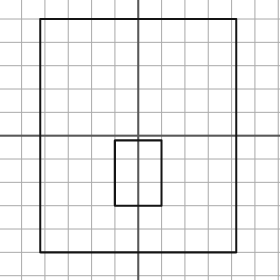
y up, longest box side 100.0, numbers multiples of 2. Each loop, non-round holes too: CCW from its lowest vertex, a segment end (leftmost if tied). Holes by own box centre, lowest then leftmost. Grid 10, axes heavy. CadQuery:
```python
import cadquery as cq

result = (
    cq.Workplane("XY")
    .moveTo(-42.0, -50.0)
    .lineTo(42.0, -50.0)
    .lineTo(42.0, 50.0)
    .lineTo(-42.0, 50.0)
    .close()
    .moveTo(-10.0, -30.0)
    .lineTo(10.0, -30.0)
    .lineTo(10.0, -2.0)
    .lineTo(-10.0, -2.0)
    .close()
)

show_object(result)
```